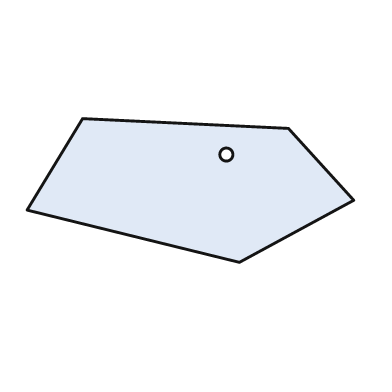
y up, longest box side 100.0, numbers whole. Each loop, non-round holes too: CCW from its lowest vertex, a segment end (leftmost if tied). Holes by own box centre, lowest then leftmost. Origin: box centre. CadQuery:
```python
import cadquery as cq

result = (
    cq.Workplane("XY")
    .moveTo(15.0, -22.0)
    .lineTo(50.0, -3.0)
    .lineTo(30.0, 19.0)
    .lineTo(-33.0, 22.0)
    .lineTo(-50.0, -6.0)
    .close()
    .moveTo(11.0, 11.0)
    .circle(2.0)
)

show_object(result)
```